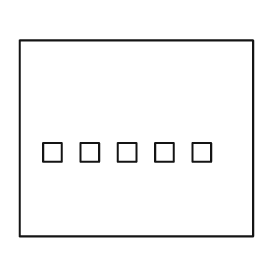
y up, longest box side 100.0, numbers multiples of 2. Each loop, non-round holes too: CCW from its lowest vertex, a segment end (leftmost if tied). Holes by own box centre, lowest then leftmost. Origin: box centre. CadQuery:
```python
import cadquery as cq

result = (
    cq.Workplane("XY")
    .moveTo(-50.0, -42.0)
    .lineTo(50.0, -42.0)
    .lineTo(50.0, 42.0)
    .lineTo(-50.0, 42.0)
    .close()
    .moveTo(-40.0, -10.0)
    .lineTo(-32.0, -10.0)
    .lineTo(-32.0, -2.0)
    .lineTo(-40.0, -2.0)
    .close()
    .moveTo(-24.0, -10.0)
    .lineTo(-16.0, -10.0)
    .lineTo(-16.0, -2.0)
    .lineTo(-24.0, -2.0)
    .close()
    .moveTo(-8.0, -10.0)
    .lineTo(0.0, -10.0)
    .lineTo(0.0, -2.0)
    .lineTo(-8.0, -2.0)
    .close()
    .moveTo(8.0, -10.0)
    .lineTo(16.0, -10.0)
    .lineTo(16.0, -2.0)
    .lineTo(8.0, -2.0)
    .close()
    .moveTo(24.0, -10.0)
    .lineTo(32.0, -10.0)
    .lineTo(32.0, -2.0)
    .lineTo(24.0, -2.0)
    .close()
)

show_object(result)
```